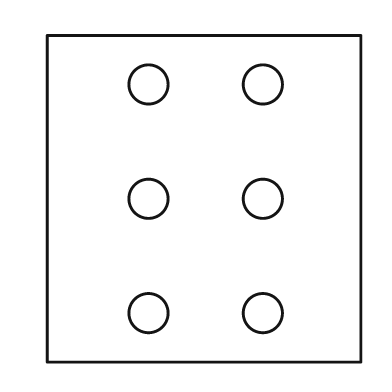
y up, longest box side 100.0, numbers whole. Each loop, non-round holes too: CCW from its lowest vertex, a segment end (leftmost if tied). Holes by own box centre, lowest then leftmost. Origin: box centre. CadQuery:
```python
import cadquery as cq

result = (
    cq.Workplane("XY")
    .moveTo(-48.0, -50.0)
    .lineTo(48.0, -50.0)
    .lineTo(48.0, 50.0)
    .lineTo(-48.0, 50.0)
    .close()
    .moveTo(-17.0, -35.0)
    .circle(6.0)
    .moveTo(18.0, -35.0)
    .circle(6.0)
    .moveTo(-17.0, 0.0)
    .circle(6.0)
    .moveTo(18.0, 0.0)
    .circle(6.0)
    .moveTo(-17.0, 35.0)
    .circle(6.0)
    .moveTo(18.0, 35.0)
    .circle(6.0)
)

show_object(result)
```